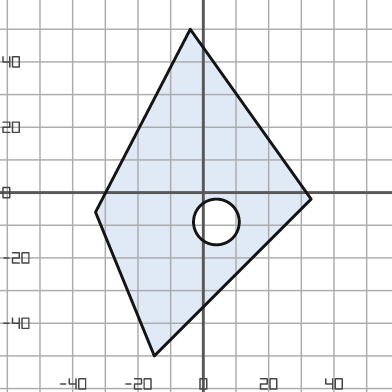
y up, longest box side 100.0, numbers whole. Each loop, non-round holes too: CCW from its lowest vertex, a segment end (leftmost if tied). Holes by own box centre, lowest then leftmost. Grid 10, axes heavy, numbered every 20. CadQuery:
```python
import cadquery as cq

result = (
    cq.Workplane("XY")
    .moveTo(-15.0, -50.0)
    .lineTo(33.0, -2.0)
    .lineTo(-4.0, 50.0)
    .lineTo(-33.0, -6.0)
    .close()
    .moveTo(4.0, -9.0)
    .circle(7.0)
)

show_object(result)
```